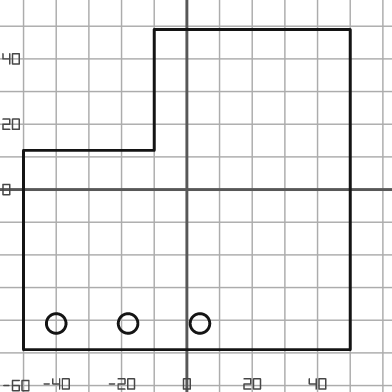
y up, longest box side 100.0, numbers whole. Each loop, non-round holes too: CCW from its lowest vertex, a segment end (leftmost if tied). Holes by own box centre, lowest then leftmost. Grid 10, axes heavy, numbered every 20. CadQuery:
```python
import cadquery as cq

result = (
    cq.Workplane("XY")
    .moveTo(-50.0, -49.0)
    .lineTo(50.0, -49.0)
    .lineTo(50.0, 49.0)
    .lineTo(-10.0, 49.0)
    .lineTo(-10.0, 12.0)
    .lineTo(-50.0, 12.0)
    .close()
    .moveTo(-40.0, -41.0)
    .circle(3.0)
    .moveTo(-18.0, -41.0)
    .circle(3.0)
    .moveTo(4.0, -41.0)
    .circle(3.0)
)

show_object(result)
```